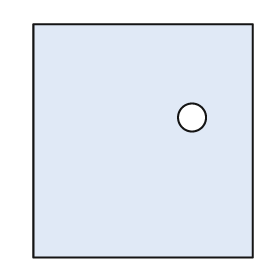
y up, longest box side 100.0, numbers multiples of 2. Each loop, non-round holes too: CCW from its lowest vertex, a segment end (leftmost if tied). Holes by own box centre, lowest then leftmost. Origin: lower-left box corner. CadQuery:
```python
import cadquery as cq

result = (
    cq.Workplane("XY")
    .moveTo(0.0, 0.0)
    .lineTo(94.0, 0.0)
    .lineTo(94.0, 100.0)
    .lineTo(0.0, 100.0)
    .close()
    .moveTo(68.0, 60.0)
    .circle(6.0)
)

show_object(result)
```